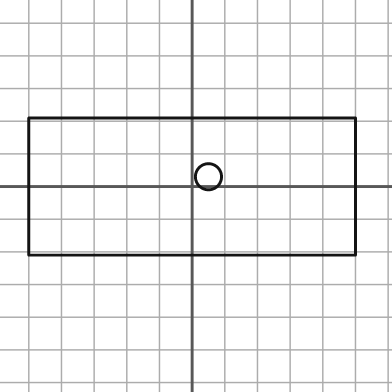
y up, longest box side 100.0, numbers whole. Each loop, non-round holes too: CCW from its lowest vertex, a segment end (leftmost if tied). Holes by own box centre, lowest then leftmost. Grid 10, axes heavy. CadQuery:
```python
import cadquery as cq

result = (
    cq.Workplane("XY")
    .moveTo(-50.0, -21.0)
    .lineTo(50.0, -21.0)
    .lineTo(50.0, 21.0)
    .lineTo(-50.0, 21.0)
    .close()
    .moveTo(5.0, 3.0)
    .circle(4.0)
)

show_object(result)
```